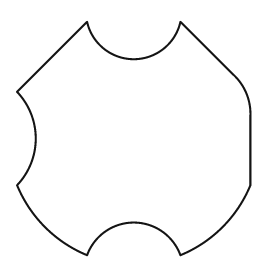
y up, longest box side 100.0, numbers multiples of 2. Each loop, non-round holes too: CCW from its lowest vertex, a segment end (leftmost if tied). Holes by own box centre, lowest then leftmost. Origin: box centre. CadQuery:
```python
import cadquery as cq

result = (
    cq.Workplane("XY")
    .moveTo(-20.0, -50.0)
    .threePointArc((0.0, -36.0), (20.0, -50.0))
    .threePointArc((38.0, -38.0), (50.0, -20.0))
    .lineTo(50.0, 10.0)
    .threePointArc((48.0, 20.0), (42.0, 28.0))
    .lineTo(20.0, 50.0)
    .threePointArc((0.0, 34.0), (-20.0, 50.0))
    .lineTo(-50.0, 20.0)
    .threePointArc((-42.0, 0.0), (-50.0, -20.0))
    .threePointArc((-38.0, -38.0), (-20.0, -50.0))
    .close()
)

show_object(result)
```